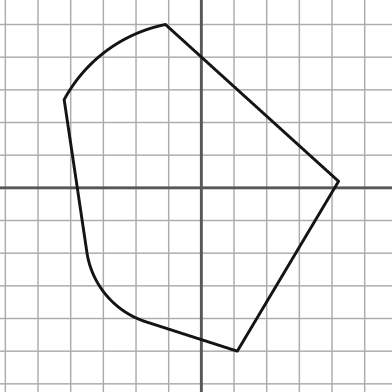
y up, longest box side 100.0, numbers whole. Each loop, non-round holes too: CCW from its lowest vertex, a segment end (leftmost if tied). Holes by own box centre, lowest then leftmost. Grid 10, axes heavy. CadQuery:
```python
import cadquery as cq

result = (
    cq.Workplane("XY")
    .moveTo(11.0, -50.0)
    .lineTo(42.0, 2.0)
    .lineTo(-11.0, 50.0)
    .threePointArc((-29.0, 42.0), (-42.0, 27.0))
    .lineTo(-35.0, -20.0)
    .threePointArc((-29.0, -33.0), (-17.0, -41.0))
    .close()
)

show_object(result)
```